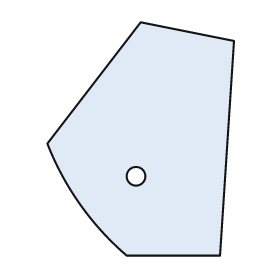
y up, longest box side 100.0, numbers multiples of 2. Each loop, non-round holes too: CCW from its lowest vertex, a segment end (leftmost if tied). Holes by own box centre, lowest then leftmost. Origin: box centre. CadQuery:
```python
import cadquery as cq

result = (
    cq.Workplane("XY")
    .moveTo(-6.0, -50.0)
    .lineTo(34.0, -50.0)
    .lineTo(40.0, 42.0)
    .lineTo(0.0, 50.0)
    .lineTo(-40.0, -2.0)
    .threePointArc((-26.0, -28.0), (-6.0, -50.0))
    .close()
    .moveTo(-2.0, -16.0)
    .circle(4.0)
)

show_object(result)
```